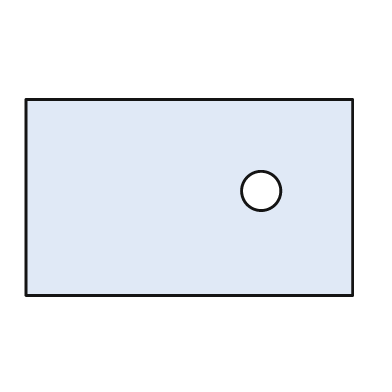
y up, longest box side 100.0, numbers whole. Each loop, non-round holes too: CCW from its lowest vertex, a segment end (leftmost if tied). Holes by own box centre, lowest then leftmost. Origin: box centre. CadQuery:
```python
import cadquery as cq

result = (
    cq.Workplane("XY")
    .moveTo(-50.0, -30.0)
    .lineTo(50.0, -30.0)
    .lineTo(50.0, 30.0)
    .lineTo(-50.0, 30.0)
    .close()
    .moveTo(22.0, 2.0)
    .circle(6.0)
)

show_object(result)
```